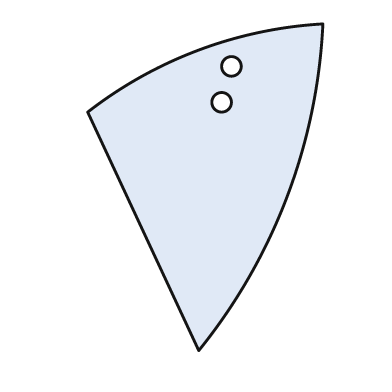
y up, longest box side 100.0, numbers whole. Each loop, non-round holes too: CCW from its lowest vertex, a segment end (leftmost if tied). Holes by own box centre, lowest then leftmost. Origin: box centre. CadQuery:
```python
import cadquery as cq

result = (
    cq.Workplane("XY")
    .moveTo(-2.0, -50.0)
    .threePointArc((25.0, -3.0), (36.0, 50.0))
    .threePointArc((-2.0, 42.0), (-36.0, 23.0))
    .close()
    .moveTo(5.0, 26.0)
    .circle(3.0)
    .moveTo(8.0, 37.0)
    .circle(3.0)
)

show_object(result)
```